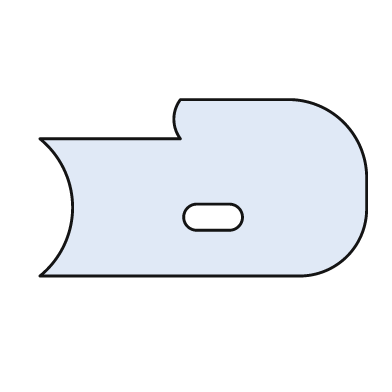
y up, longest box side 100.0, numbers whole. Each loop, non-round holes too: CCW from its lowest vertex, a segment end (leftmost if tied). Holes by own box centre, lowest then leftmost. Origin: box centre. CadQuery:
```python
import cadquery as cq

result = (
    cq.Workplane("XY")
    .moveTo(-50.0, -27.0)
    .lineTo(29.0, -27.0)
    .threePointArc((44.0, -21.0), (50.0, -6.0))
    .lineTo(50.0, 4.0)
    .threePointArc((43.0, 20.0), (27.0, 27.0))
    .lineTo(-7.0, 27.0)
    .threePointArc((-9.0, 21.0), (-7.0, 15.0))
    .lineTo(-50.0, 15.0)
    .threePointArc((-40.0, -6.0), (-50.0, -27.0))
    .close()
    .moveTo(-2.0, -13.0)
    .lineTo(8.0, -13.0)
    .threePointArc((12.0, -9.0), (8.0, -5.0))
    .lineTo(-2.0, -5.0)
    .threePointArc((-6.0, -9.0), (-2.0, -13.0))
    .close()
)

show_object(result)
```